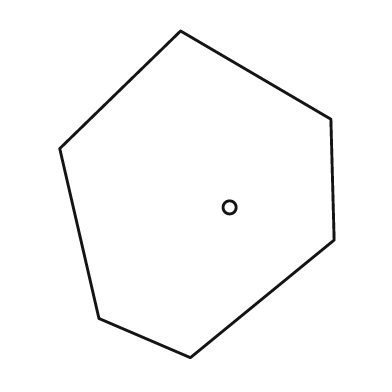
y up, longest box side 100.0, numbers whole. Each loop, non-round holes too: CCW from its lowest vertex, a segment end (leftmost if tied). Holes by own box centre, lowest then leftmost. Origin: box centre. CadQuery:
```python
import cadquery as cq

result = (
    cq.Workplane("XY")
    .moveTo(-2.0, -50.0)
    .lineTo(42.0, -14.0)
    .lineTo(41.0, 23.0)
    .lineTo(-5.0, 50.0)
    .lineTo(-42.0, 14.0)
    .lineTo(-30.0, -38.0)
    .close()
    .moveTo(10.0, -4.0)
    .circle(2.0)
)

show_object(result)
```